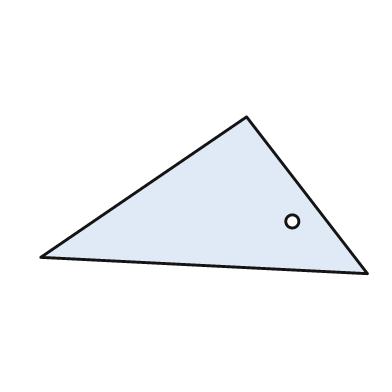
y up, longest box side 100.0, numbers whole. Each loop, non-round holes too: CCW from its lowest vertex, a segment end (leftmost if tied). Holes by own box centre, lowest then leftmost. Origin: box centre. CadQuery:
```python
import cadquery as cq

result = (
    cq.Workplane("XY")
    .moveTo(50.0, -24.0)
    .lineTo(13.0, 24.0)
    .lineTo(-50.0, -19.0)
    .close()
    .moveTo(27.0, -8.0)
    .circle(2.0)
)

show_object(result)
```